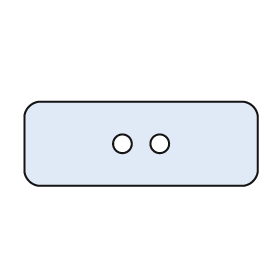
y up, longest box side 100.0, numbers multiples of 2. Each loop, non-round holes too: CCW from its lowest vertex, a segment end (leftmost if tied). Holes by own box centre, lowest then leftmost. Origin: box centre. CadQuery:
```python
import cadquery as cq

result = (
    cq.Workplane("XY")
    .moveTo(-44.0, -18.0)
    .lineTo(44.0, -18.0)
    .threePointArc((48.0, -16.0), (50.0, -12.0))
    .lineTo(50.0, 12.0)
    .threePointArc((48.0, 16.0), (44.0, 18.0))
    .lineTo(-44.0, 18.0)
    .threePointArc((-48.0, 16.0), (-50.0, 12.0))
    .lineTo(-50.0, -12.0)
    .threePointArc((-48.0, -16.0), (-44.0, -18.0))
    .close()
    .moveTo(-8.0, 0.0)
    .circle(4.0)
    .moveTo(8.0, 0.0)
    .circle(4.0)
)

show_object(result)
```